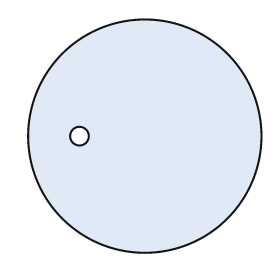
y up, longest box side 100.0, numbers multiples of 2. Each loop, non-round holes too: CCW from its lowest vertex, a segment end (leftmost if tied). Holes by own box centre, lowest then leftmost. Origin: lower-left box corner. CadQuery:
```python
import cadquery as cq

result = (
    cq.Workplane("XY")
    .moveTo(50.0, 50.0)
    .circle(50.0)
    .moveTo(22.0, 50.0)
    .circle(4.0)
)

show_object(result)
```